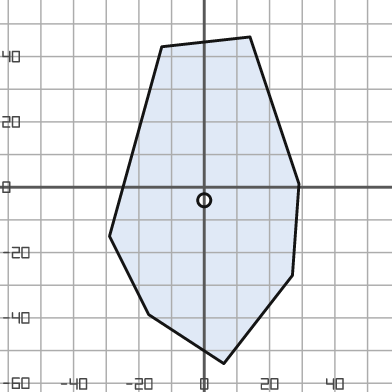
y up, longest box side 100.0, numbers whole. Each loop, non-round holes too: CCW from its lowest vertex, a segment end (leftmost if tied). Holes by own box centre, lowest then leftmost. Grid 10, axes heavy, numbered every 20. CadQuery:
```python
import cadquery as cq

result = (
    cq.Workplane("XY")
    .moveTo(6.0, -54.0)
    .lineTo(27.0, -27.0)
    .lineTo(29.0, 1.0)
    .lineTo(14.0, 46.0)
    .lineTo(-13.0, 43.0)
    .lineTo(-29.0, -15.0)
    .lineTo(-17.0, -39.0)
    .close()
    .moveTo(0.0, -4.0)
    .circle(2.0)
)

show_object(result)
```